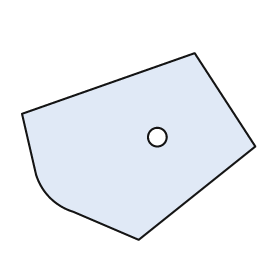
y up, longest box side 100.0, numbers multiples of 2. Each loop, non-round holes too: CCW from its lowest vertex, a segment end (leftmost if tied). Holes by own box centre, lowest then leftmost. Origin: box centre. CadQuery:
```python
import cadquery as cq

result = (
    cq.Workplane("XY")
    .moveTo(0.0, -40.0)
    .lineTo(50.0, 0.0)
    .lineTo(24.0, 40.0)
    .lineTo(-50.0, 14.0)
    .lineTo(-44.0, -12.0)
    .threePointArc((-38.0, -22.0), (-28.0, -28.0))
    .close()
    .moveTo(8.0, 4.0)
    .circle(4.0)
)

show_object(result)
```